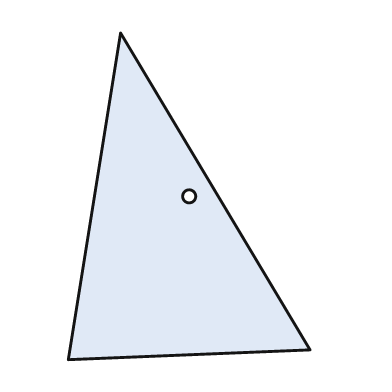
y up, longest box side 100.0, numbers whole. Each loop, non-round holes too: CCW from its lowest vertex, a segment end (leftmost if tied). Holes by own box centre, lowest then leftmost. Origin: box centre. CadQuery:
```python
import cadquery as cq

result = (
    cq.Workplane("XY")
    .moveTo(-37.0, -50.0)
    .lineTo(37.0, -47.0)
    .lineTo(-21.0, 50.0)
    .close()
    .moveTo(0.0, 0.0)
    .circle(2.0)
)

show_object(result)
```